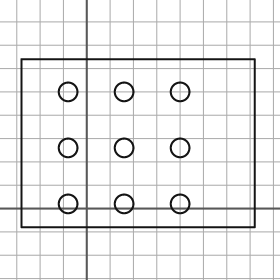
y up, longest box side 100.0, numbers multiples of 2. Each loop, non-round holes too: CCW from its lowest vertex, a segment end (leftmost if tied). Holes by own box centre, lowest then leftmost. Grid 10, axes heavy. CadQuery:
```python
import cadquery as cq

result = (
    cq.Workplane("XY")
    .moveTo(-28.0, -8.0)
    .lineTo(72.0, -8.0)
    .lineTo(72.0, 64.0)
    .lineTo(-28.0, 64.0)
    .close()
    .moveTo(-8.0, 2.0)
    .circle(4.0)
    .moveTo(16.0, 2.0)
    .circle(4.0)
    .moveTo(40.0, 2.0)
    .circle(4.0)
    .moveTo(-8.0, 26.0)
    .circle(4.0)
    .moveTo(16.0, 26.0)
    .circle(4.0)
    .moveTo(40.0, 26.0)
    .circle(4.0)
    .moveTo(-8.0, 50.0)
    .circle(4.0)
    .moveTo(16.0, 50.0)
    .circle(4.0)
    .moveTo(40.0, 50.0)
    .circle(4.0)
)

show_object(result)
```